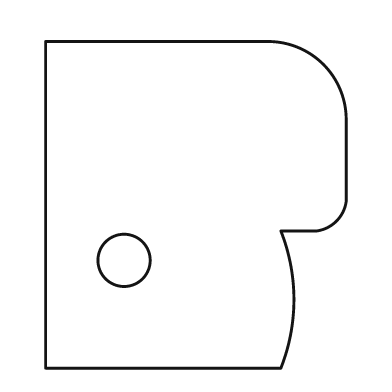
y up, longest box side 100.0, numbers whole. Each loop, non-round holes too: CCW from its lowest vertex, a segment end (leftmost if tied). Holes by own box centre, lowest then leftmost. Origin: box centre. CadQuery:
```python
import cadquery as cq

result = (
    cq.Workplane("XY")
    .moveTo(-46.0, -50.0)
    .lineTo(26.0, -50.0)
    .threePointArc((30.0, -29.0), (26.0, -8.0))
    .lineTo(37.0, -8.0)
    .threePointArc((43.0, -5.0), (46.0, 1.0))
    .lineTo(46.0, 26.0)
    .threePointArc((39.0, 43.0), (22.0, 50.0))
    .lineTo(-46.0, 50.0)
    .close()
    .moveTo(-22.0, -17.0)
    .circle(8.0)
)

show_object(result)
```